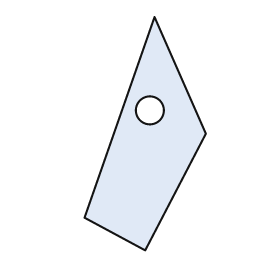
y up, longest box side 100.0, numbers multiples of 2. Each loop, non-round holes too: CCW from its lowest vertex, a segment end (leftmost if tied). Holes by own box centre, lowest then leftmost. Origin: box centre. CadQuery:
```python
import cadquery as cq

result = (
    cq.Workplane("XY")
    .moveTo(0.0, -50.0)
    .lineTo(26.0, 0.0)
    .lineTo(4.0, 50.0)
    .lineTo(-26.0, -36.0)
    .close()
    .moveTo(2.0, 10.0)
    .circle(6.0)
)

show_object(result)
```